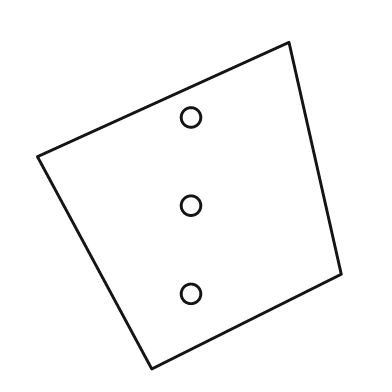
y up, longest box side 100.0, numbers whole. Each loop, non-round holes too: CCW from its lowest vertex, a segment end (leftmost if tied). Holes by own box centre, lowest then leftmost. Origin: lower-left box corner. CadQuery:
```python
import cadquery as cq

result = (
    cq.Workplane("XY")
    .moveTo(35.0, 0.0)
    .lineTo(93.0, 29.0)
    .lineTo(77.0, 100.0)
    .lineTo(0.0, 65.0)
    .close()
    .moveTo(47.0, 23.0)
    .circle(3.0)
    .moveTo(47.0, 50.0)
    .circle(3.0)
    .moveTo(47.0, 77.0)
    .circle(3.0)
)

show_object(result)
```